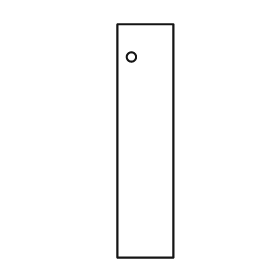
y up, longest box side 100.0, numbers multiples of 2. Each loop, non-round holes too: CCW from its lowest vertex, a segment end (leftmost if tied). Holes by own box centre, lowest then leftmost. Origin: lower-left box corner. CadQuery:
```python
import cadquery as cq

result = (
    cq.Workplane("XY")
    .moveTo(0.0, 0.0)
    .lineTo(24.0, 0.0)
    .lineTo(24.0, 100.0)
    .lineTo(0.0, 100.0)
    .close()
    .moveTo(6.0, 86.0)
    .circle(2.0)
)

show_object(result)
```